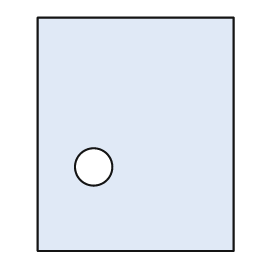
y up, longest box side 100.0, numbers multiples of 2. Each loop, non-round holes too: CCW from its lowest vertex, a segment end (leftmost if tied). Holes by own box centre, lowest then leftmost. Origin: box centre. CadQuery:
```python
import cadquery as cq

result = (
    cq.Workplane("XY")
    .moveTo(-42.0, -50.0)
    .lineTo(42.0, -50.0)
    .lineTo(42.0, 50.0)
    .lineTo(-42.0, 50.0)
    .close()
    .moveTo(-18.0, -14.0)
    .circle(8.0)
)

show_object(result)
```